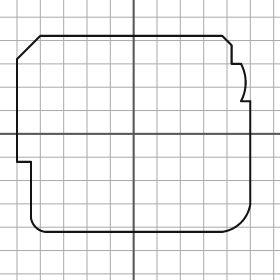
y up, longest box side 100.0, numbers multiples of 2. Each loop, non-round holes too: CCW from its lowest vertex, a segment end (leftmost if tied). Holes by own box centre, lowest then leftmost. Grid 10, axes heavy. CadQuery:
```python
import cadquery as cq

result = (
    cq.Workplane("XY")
    .moveTo(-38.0, -42.0)
    .lineTo(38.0, -42.0)
    .threePointArc((46.0, -38.0), (50.0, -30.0))
    .lineTo(50.0, 14.0)
    .lineTo(46.0, 14.0)
    .threePointArc((48.0, 22.0), (46.0, 30.0))
    .lineTo(42.0, 30.0)
    .lineTo(42.0, 38.0)
    .lineTo(38.0, 42.0)
    .lineTo(-40.0, 42.0)
    .lineTo(-50.0, 32.0)
    .lineTo(-50.0, -12.0)
    .lineTo(-44.0, -12.0)
    .lineTo(-44.0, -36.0)
    .threePointArc((-42.0, -40.0), (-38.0, -42.0))
    .close()
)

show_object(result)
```